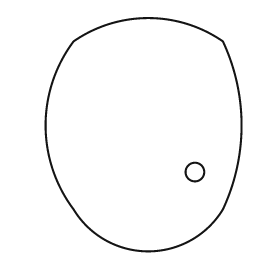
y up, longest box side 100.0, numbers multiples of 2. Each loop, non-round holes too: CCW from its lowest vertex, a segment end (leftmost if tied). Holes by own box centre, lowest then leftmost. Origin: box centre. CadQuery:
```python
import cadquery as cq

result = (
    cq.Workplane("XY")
    .moveTo(-30.0, -32.0)
    .threePointArc((2.0, -50.0), (34.0, -32.0))
    .threePointArc((42.0, 4.0), (34.0, 40.0))
    .threePointArc((2.0, 50.0), (-30.0, 40.0))
    .threePointArc((-42.0, 4.0), (-30.0, -32.0))
    .close()
    .moveTo(22.0, -16.0)
    .circle(4.0)
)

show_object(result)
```